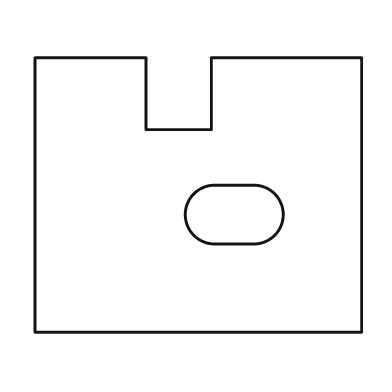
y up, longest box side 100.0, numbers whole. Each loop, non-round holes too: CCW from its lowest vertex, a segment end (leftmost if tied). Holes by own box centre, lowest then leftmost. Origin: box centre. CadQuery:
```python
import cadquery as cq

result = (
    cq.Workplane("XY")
    .moveTo(-50.0, -42.0)
    .lineTo(50.0, -42.0)
    .lineTo(50.0, 42.0)
    .lineTo(4.0, 42.0)
    .lineTo(4.0, 20.0)
    .lineTo(-16.0, 20.0)
    .lineTo(-16.0, 42.0)
    .lineTo(-50.0, 42.0)
    .close()
    .moveTo(5.0, -15.0)
    .lineTo(17.0, -15.0)
    .threePointArc((26.0, -6.0), (17.0, 3.0))
    .lineTo(5.0, 3.0)
    .threePointArc((-4.0, -6.0), (5.0, -15.0))
    .close()
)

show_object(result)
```